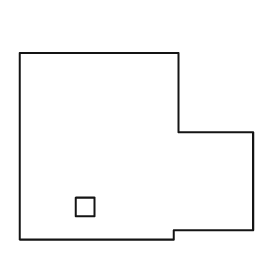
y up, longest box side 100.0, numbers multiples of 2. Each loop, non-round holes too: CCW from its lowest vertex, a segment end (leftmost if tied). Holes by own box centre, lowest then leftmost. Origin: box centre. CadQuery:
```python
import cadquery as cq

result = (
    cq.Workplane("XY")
    .moveTo(-50.0, -40.0)
    .lineTo(16.0, -40.0)
    .lineTo(16.0, -36.0)
    .lineTo(50.0, -36.0)
    .lineTo(50.0, 6.0)
    .lineTo(18.0, 6.0)
    .lineTo(18.0, 40.0)
    .lineTo(-50.0, 40.0)
    .close()
    .moveTo(-26.0, -30.0)
    .lineTo(-18.0, -30.0)
    .lineTo(-18.0, -22.0)
    .lineTo(-26.0, -22.0)
    .close()
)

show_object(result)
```